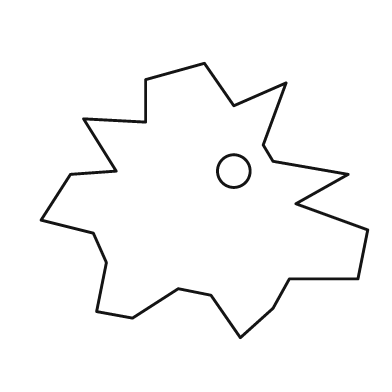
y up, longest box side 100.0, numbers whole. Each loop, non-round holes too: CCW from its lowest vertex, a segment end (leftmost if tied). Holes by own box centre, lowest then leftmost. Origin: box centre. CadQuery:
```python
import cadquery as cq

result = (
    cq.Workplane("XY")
    .moveTo(11.0, -42.0)
    .lineTo(21.0, -33.0)
    .lineTo(26.0, -24.0)
    .lineTo(47.0, -24.0)
    .lineTo(50.0, -9.0)
    .lineTo(28.0, -1.0)
    .lineTo(44.0, 8.0)
    .lineTo(21.0, 12.0)
    .lineTo(18.0, 17.0)
    .lineTo(25.0, 36.0)
    .lineTo(9.0, 29.0)
    .lineTo(0.0, 42.0)
    .lineTo(-18.0, 37.0)
    .lineTo(-18.0, 24.0)
    .lineTo(-37.0, 25.0)
    .lineTo(-27.0, 9.0)
    .lineTo(-41.0, 8.0)
    .lineTo(-50.0, -6.0)
    .lineTo(-34.0, -10.0)
    .lineTo(-30.0, -19.0)
    .lineTo(-33.0, -34.0)
    .lineTo(-22.0, -36.0)
    .lineTo(-8.0, -27.0)
    .lineTo(2.0, -29.0)
    .close()
    .moveTo(9.0, 9.0)
    .circle(5.0)
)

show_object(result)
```